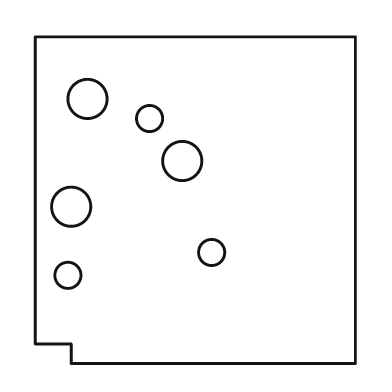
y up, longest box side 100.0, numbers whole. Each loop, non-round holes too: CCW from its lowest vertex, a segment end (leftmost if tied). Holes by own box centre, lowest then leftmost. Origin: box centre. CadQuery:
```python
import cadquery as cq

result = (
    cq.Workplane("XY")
    .moveTo(-38.0, -50.0)
    .lineTo(49.0, -50.0)
    .lineTo(49.0, 50.0)
    .lineTo(-49.0, 50.0)
    .lineTo(-49.0, -44.0)
    .lineTo(-38.0, -44.0)
    .close()
    .moveTo(-39.0, -23.0)
    .circle(4.0)
    .moveTo(5.0, -16.0)
    .circle(4.0)
    .moveTo(-38.0, -2.0)
    .circle(6.0)
    .moveTo(-4.0, 12.0)
    .circle(6.0)
    .moveTo(-14.0, 25.0)
    .circle(4.0)
    .moveTo(-33.0, 31.0)
    .circle(6.0)
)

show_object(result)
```